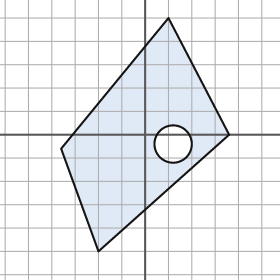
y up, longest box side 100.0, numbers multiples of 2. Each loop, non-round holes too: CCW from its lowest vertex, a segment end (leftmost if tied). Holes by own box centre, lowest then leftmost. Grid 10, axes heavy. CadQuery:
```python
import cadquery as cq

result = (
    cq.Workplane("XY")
    .moveTo(-20.0, -50.0)
    .lineTo(36.0, 0.0)
    .lineTo(10.0, 50.0)
    .lineTo(-36.0, -6.0)
    .close()
    .moveTo(12.0, -4.0)
    .circle(8.0)
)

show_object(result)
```